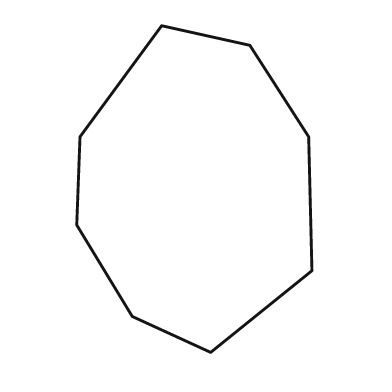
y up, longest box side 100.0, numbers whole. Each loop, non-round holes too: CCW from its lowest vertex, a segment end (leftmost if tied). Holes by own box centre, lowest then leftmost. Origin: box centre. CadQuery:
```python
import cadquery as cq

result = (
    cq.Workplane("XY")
    .moveTo(5.0, -50.0)
    .lineTo(36.0, -25.0)
    .lineTo(35.0, 16.0)
    .lineTo(17.0, 44.0)
    .lineTo(-10.0, 50.0)
    .lineTo(-35.0, 16.0)
    .lineTo(-36.0, -11.0)
    .lineTo(-19.0, -39.0)
    .close()
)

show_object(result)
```